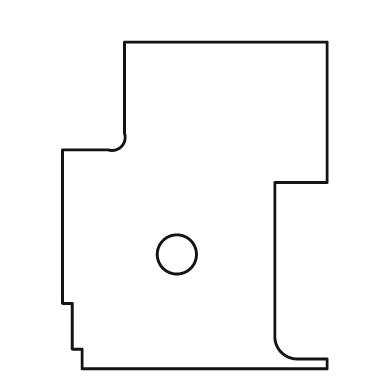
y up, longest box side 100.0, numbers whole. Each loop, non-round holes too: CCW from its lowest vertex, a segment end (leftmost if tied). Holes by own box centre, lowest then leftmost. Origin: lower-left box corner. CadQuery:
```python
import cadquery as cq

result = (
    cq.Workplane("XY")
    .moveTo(6.0, 0.0)
    .lineTo(81.0, 0.0)
    .lineTo(81.0, 3.0)
    .lineTo(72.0, 3.0)
    .threePointArc((67.0, 5.0), (65.0, 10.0))
    .lineTo(65.0, 57.0)
    .lineTo(81.0, 57.0)
    .lineTo(81.0, 100.0)
    .lineTo(19.0, 100.0)
    .lineTo(19.0, 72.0)
    .threePointArc((18.0, 68.0), (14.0, 67.0))
    .lineTo(0.0, 67.0)
    .lineTo(0.0, 20.0)
    .lineTo(3.0, 20.0)
    .lineTo(3.0, 6.0)
    .lineTo(6.0, 6.0)
    .close()
    .moveTo(35.0, 35.0)
    .circle(6.0)
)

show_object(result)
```